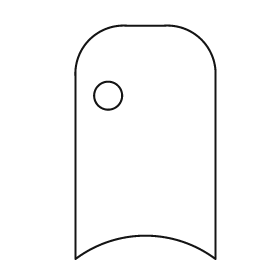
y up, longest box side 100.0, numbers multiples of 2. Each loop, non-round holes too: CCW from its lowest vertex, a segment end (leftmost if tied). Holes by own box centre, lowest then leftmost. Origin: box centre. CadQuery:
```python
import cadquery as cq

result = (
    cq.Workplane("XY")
    .moveTo(-30.0, -50.0)
    .threePointArc((0.0, -40.0), (30.0, -50.0))
    .lineTo(30.0, 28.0)
    .threePointArc((24.0, 44.0), (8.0, 50.0))
    .lineTo(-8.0, 50.0)
    .threePointArc((-24.0, 44.0), (-30.0, 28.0))
    .close()
    .moveTo(-16.0, 20.0)
    .circle(6.0)
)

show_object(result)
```